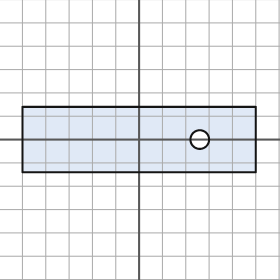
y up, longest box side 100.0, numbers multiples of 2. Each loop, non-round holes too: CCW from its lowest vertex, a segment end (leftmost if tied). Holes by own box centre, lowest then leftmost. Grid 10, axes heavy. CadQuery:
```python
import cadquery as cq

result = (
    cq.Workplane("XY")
    .moveTo(-50.0, -14.0)
    .lineTo(50.0, -14.0)
    .lineTo(50.0, 14.0)
    .lineTo(-50.0, 14.0)
    .close()
    .moveTo(26.0, 0.0)
    .circle(4.0)
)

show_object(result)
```